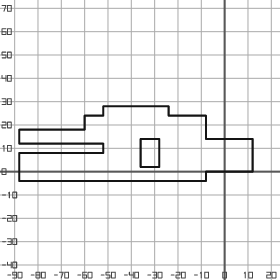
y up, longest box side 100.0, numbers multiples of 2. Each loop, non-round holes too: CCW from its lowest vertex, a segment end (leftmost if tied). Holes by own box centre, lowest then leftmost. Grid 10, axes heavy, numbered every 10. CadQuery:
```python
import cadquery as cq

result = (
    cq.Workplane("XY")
    .moveTo(-88.0, -4.0)
    .lineTo(-8.0, -4.0)
    .lineTo(-8.0, 0.0)
    .lineTo(12.0, 0.0)
    .lineTo(12.0, 14.0)
    .lineTo(-8.0, 14.0)
    .lineTo(-8.0, 24.0)
    .lineTo(-24.0, 24.0)
    .lineTo(-24.0, 28.0)
    .lineTo(-52.0, 28.0)
    .lineTo(-52.0, 24.0)
    .lineTo(-60.0, 24.0)
    .lineTo(-60.0, 18.0)
    .lineTo(-88.0, 18.0)
    .lineTo(-88.0, 12.0)
    .lineTo(-52.0, 12.0)
    .lineTo(-52.0, 8.0)
    .lineTo(-88.0, 8.0)
    .close()
    .moveTo(-36.0, 2.0)
    .lineTo(-28.0, 2.0)
    .lineTo(-28.0, 14.0)
    .lineTo(-36.0, 14.0)
    .close()
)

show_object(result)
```